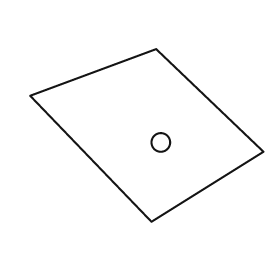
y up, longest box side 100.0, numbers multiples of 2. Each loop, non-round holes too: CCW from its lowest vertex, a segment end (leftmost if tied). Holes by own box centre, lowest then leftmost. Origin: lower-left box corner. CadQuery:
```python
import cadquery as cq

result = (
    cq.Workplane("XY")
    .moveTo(52.0, 0.0)
    .lineTo(100.0, 30.0)
    .lineTo(54.0, 74.0)
    .lineTo(0.0, 54.0)
    .close()
    .moveTo(56.0, 34.0)
    .circle(4.0)
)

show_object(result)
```